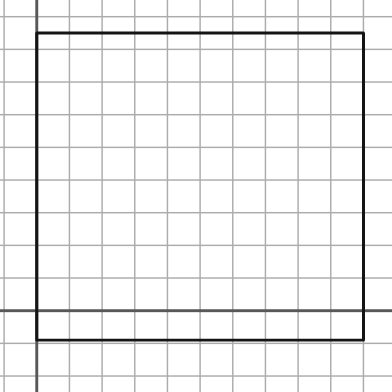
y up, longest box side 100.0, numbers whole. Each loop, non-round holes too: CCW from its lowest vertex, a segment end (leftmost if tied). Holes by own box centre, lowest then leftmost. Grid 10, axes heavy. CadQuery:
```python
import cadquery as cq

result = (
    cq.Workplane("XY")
    .moveTo(0.0, -9.0)
    .lineTo(100.0, -9.0)
    .lineTo(100.0, 85.0)
    .lineTo(0.0, 85.0)
    .close()
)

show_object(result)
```